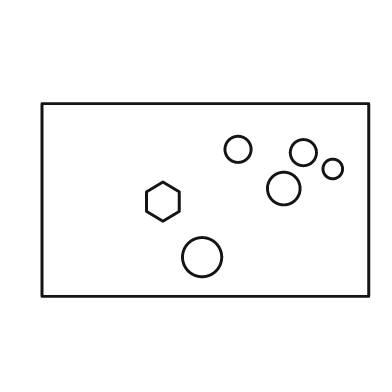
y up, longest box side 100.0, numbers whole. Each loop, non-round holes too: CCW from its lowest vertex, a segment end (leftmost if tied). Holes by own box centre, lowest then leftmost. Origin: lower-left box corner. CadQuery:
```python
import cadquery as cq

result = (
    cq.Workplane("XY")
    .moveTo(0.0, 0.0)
    .lineTo(100.0, 0.0)
    .lineTo(100.0, 59.0)
    .lineTo(0.0, 59.0)
    .close()
    .moveTo(49.0, 12.0)
    .circle(6.0)
    .moveTo(37.0, 23.0)
    .lineTo(42.0, 26.0)
    .lineTo(42.0, 32.0)
    .lineTo(37.0, 35.0)
    .lineTo(32.0, 32.0)
    .lineTo(32.0, 26.0)
    .close()
    .moveTo(74.0, 33.0)
    .circle(5.0)
    .moveTo(89.0, 39.0)
    .circle(3.0)
    .moveTo(80.0, 44.0)
    .circle(4.0)
    .moveTo(60.0, 45.0)
    .circle(4.0)
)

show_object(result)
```